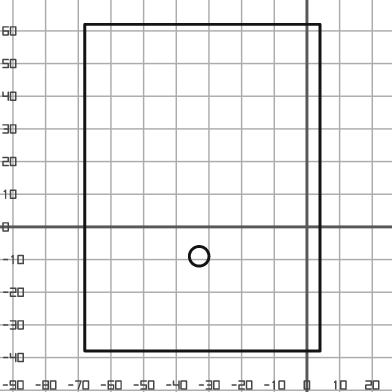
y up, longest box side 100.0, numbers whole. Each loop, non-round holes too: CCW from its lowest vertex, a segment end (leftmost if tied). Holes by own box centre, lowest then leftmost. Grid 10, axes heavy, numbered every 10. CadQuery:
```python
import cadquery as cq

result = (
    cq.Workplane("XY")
    .moveTo(-68.0, -38.0)
    .lineTo(4.0, -38.0)
    .lineTo(4.0, 62.0)
    .lineTo(-68.0, 62.0)
    .close()
    .moveTo(-33.0, -9.0)
    .circle(3.0)
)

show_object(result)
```